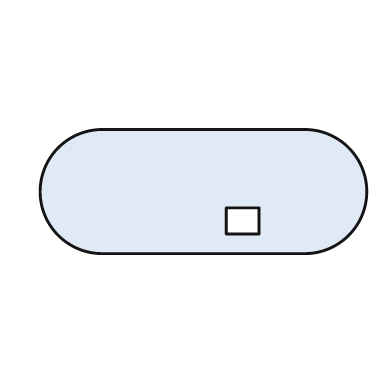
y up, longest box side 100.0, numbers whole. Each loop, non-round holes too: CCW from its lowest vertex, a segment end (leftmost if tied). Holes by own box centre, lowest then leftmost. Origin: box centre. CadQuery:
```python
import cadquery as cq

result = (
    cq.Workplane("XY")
    .moveTo(-31.0, -19.0)
    .lineTo(31.0, -19.0)
    .threePointArc((50.0, 0.0), (31.0, 19.0))
    .lineTo(-31.0, 19.0)
    .threePointArc((-50.0, 0.0), (-31.0, -19.0))
    .close()
    .moveTo(7.0, -13.0)
    .lineTo(17.0, -13.0)
    .lineTo(17.0, -5.0)
    .lineTo(7.0, -5.0)
    .close()
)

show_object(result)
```